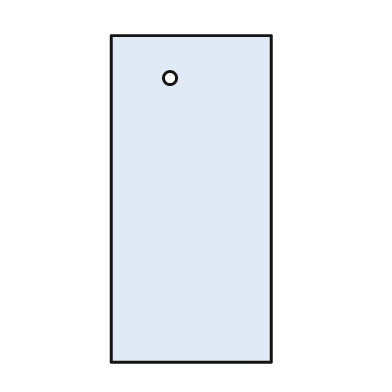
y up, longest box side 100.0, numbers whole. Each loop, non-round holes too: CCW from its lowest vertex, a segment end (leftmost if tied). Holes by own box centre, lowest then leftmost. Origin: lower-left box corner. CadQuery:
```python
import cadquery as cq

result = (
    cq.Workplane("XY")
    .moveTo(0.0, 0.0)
    .lineTo(49.0, 0.0)
    .lineTo(49.0, 100.0)
    .lineTo(0.0, 100.0)
    .close()
    .moveTo(18.0, 87.0)
    .circle(2.0)
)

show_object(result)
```